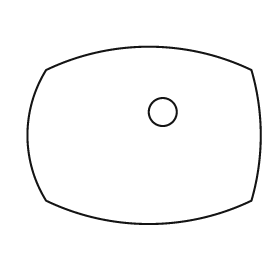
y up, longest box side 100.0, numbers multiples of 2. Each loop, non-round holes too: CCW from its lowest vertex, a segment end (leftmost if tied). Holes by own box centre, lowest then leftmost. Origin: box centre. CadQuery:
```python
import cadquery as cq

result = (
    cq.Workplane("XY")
    .moveTo(-42.0, -28.0)
    .threePointArc((2.0, -38.0), (46.0, -28.0))
    .threePointArc((50.0, 0.0), (46.0, 28.0))
    .threePointArc((2.0, 38.0), (-42.0, 28.0))
    .threePointArc((-50.0, 0.0), (-42.0, -28.0))
    .close()
    .moveTo(8.0, 10.0)
    .circle(6.0)
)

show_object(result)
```